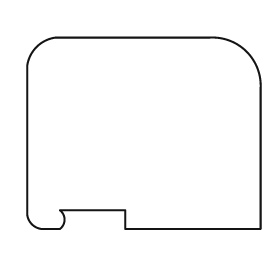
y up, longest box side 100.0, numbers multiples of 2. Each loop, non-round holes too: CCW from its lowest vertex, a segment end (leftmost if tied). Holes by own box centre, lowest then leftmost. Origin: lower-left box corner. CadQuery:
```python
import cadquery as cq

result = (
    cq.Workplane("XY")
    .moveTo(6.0, 0.0)
    .lineTo(14.0, 0.0)
    .threePointArc((16.0, 4.0), (14.0, 8.0))
    .lineTo(42.0, 8.0)
    .lineTo(42.0, 0.0)
    .lineTo(100.0, 0.0)
    .lineTo(100.0, 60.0)
    .threePointArc((94.0, 76.0), (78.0, 82.0))
    .lineTo(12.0, 82.0)
    .threePointArc((4.0, 78.0), (0.0, 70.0))
    .lineTo(0.0, 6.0)
    .threePointArc((2.0, 2.0), (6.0, 0.0))
    .close()
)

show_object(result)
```